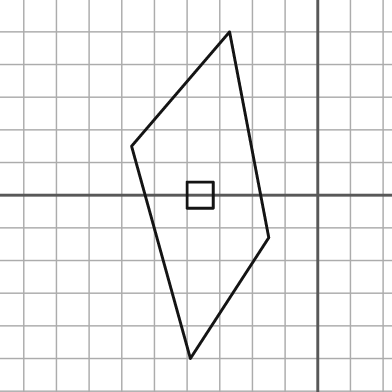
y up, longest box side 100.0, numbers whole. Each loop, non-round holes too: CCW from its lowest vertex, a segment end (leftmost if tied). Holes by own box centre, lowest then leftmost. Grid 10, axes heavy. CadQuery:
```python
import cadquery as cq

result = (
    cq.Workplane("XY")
    .moveTo(-39.0, -50.0)
    .lineTo(-15.0, -13.0)
    .lineTo(-27.0, 50.0)
    .lineTo(-57.0, 15.0)
    .close()
    .moveTo(-40.0, -4.0)
    .lineTo(-32.0, -4.0)
    .lineTo(-32.0, 4.0)
    .lineTo(-40.0, 4.0)
    .close()
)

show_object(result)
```